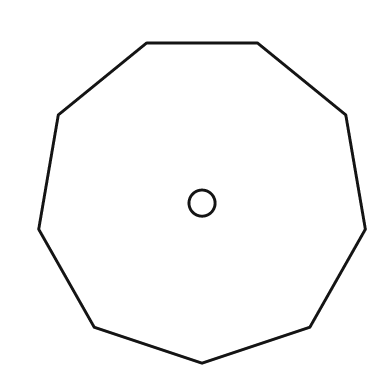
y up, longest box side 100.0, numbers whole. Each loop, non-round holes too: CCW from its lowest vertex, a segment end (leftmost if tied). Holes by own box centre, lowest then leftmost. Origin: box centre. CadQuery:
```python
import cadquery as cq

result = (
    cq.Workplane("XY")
    .moveTo(0.0, -49.0)
    .lineTo(33.0, -38.0)
    .lineTo(50.0, -8.0)
    .lineTo(44.0, 27.0)
    .lineTo(17.0, 49.0)
    .lineTo(-17.0, 49.0)
    .lineTo(-44.0, 27.0)
    .lineTo(-50.0, -8.0)
    .lineTo(-33.0, -38.0)
    .close()
    .moveTo(0.0, 0.0)
    .circle(4.0)
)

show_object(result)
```